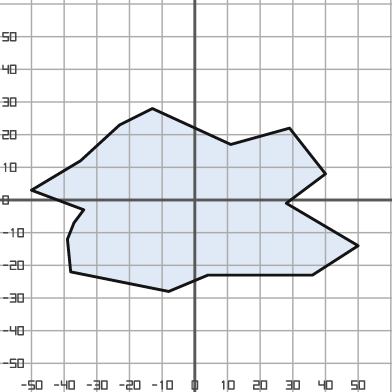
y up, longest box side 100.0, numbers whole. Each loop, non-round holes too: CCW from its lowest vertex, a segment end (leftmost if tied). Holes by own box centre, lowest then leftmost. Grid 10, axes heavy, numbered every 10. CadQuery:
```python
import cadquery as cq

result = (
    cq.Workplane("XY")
    .moveTo(-8.0, -28.0)
    .lineTo(4.0, -23.0)
    .lineTo(36.0, -23.0)
    .lineTo(50.0, -14.0)
    .lineTo(28.0, -1.0)
    .lineTo(40.0, 8.0)
    .lineTo(29.0, 22.0)
    .lineTo(11.0, 17.0)
    .lineTo(-13.0, 28.0)
    .lineTo(-23.0, 23.0)
    .lineTo(-35.0, 12.0)
    .lineTo(-50.0, 3.0)
    .lineTo(-34.0, -3.0)
    .lineTo(-37.0, -7.0)
    .lineTo(-39.0, -12.0)
    .lineTo(-38.0, -22.0)
    .close()
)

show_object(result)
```